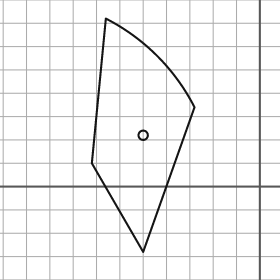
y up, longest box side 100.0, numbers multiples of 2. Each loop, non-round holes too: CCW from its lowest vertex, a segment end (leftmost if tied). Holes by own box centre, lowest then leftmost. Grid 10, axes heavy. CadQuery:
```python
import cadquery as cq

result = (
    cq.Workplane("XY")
    .moveTo(-50.0, -28.0)
    .lineTo(-28.0, 34.0)
    .threePointArc((-44.0, 56.0), (-66.0, 72.0))
    .lineTo(-72.0, 10.0)
    .close()
    .moveTo(-50.0, 22.0)
    .circle(2.0)
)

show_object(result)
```